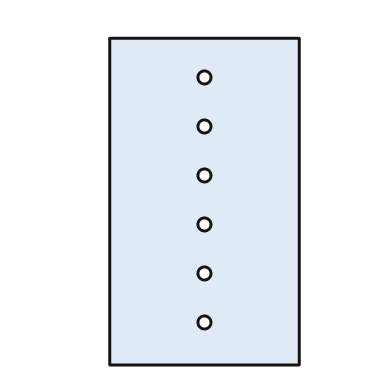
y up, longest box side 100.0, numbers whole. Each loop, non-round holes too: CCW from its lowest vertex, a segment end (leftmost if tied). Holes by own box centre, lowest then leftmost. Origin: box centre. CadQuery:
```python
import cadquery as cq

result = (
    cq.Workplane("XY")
    .moveTo(-29.0, -50.0)
    .lineTo(29.0, -50.0)
    .lineTo(29.0, 50.0)
    .lineTo(-29.0, 50.0)
    .close()
    .moveTo(0.0, -37.0)
    .circle(2.0)
    .moveTo(0.0, -22.0)
    .circle(2.0)
    .moveTo(0.0, -7.0)
    .circle(2.0)
    .moveTo(0.0, 8.0)
    .circle(2.0)
    .moveTo(0.0, 23.0)
    .circle(2.0)
    .moveTo(0.0, 38.0)
    .circle(2.0)
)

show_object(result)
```